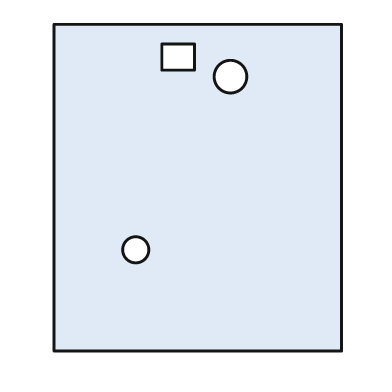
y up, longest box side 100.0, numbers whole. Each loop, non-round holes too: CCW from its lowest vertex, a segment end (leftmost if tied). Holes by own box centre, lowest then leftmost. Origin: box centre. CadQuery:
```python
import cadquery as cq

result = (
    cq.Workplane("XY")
    .moveTo(-44.0, -50.0)
    .lineTo(44.0, -50.0)
    .lineTo(44.0, 50.0)
    .lineTo(-44.0, 50.0)
    .close()
    .moveTo(-19.0, -19.0)
    .circle(4.0)
    .moveTo(10.0, 34.0)
    .circle(5.0)
    .moveTo(-11.0, 36.0)
    .lineTo(-1.0, 36.0)
    .lineTo(-1.0, 44.0)
    .lineTo(-11.0, 44.0)
    .close()
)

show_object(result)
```